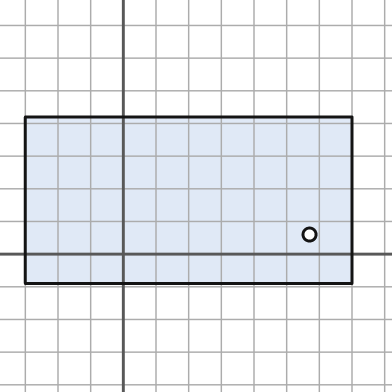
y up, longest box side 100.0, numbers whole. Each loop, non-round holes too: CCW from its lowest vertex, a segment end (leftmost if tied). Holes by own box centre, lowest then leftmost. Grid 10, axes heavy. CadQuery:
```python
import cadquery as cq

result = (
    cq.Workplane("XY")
    .moveTo(-30.0, -9.0)
    .lineTo(70.0, -9.0)
    .lineTo(70.0, 42.0)
    .lineTo(-30.0, 42.0)
    .close()
    .moveTo(57.0, 6.0)
    .circle(2.0)
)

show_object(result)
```